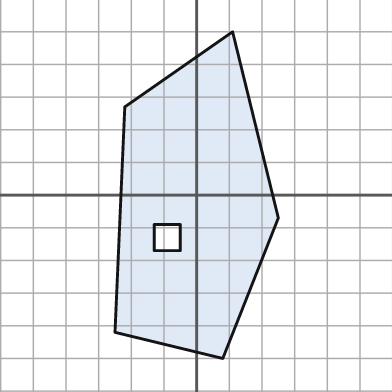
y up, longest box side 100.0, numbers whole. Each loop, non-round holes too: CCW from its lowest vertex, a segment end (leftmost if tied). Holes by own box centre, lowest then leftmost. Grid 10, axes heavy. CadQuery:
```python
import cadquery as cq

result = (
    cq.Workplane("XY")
    .moveTo(8.0, -50.0)
    .lineTo(25.0, -7.0)
    .lineTo(11.0, 50.0)
    .lineTo(-22.0, 27.0)
    .lineTo(-25.0, -42.0)
    .close()
    .moveTo(-13.0, -17.0)
    .lineTo(-5.0, -17.0)
    .lineTo(-5.0, -9.0)
    .lineTo(-13.0, -9.0)
    .close()
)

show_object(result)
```